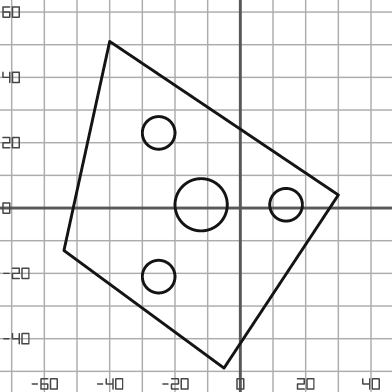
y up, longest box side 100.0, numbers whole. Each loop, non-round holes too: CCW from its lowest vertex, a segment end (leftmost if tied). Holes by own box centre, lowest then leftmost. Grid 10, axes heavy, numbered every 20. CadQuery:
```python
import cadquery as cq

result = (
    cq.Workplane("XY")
    .moveTo(-5.0, -49.0)
    .lineTo(30.0, 4.0)
    .lineTo(-40.0, 51.0)
    .lineTo(-54.0, -13.0)
    .close()
    .moveTo(-25.0, -21.0)
    .circle(5.0)
    .moveTo(-12.0, 1.0)
    .circle(8.0)
    .moveTo(14.0, 1.0)
    .circle(5.0)
    .moveTo(-25.0, 23.0)
    .circle(5.0)
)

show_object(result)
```